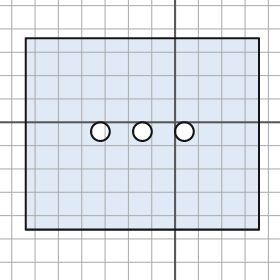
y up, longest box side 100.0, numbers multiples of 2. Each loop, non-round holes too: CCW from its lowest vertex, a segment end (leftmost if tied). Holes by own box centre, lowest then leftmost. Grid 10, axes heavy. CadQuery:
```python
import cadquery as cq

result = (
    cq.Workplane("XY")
    .moveTo(-64.0, -46.0)
    .lineTo(36.0, -46.0)
    .lineTo(36.0, 36.0)
    .lineTo(-64.0, 36.0)
    .close()
    .moveTo(-32.0, -4.0)
    .circle(4.0)
    .moveTo(-14.0, -4.0)
    .circle(4.0)
    .moveTo(4.0, -4.0)
    .circle(4.0)
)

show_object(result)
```